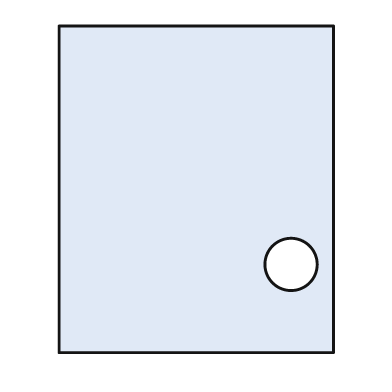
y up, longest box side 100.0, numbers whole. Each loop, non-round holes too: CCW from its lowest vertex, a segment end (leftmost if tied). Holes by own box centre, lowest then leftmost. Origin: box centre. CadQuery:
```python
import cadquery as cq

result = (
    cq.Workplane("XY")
    .moveTo(-42.0, -50.0)
    .lineTo(42.0, -50.0)
    .lineTo(42.0, 50.0)
    .lineTo(-42.0, 50.0)
    .close()
    .moveTo(29.0, -23.0)
    .circle(8.0)
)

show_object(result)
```